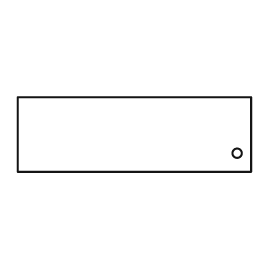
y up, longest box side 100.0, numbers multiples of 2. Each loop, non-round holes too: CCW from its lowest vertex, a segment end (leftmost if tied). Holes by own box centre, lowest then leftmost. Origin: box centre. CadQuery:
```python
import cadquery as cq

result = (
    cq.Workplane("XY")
    .moveTo(-50.0, -16.0)
    .lineTo(50.0, -16.0)
    .lineTo(50.0, 16.0)
    .lineTo(-50.0, 16.0)
    .close()
    .moveTo(44.0, -8.0)
    .circle(2.0)
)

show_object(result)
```